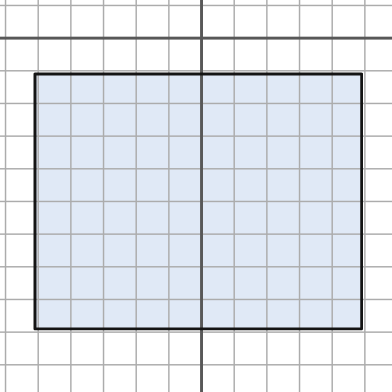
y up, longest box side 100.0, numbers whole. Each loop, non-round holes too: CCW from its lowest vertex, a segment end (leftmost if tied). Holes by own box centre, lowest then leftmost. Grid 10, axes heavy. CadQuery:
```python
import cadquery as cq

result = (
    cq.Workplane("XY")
    .moveTo(-51.0, -89.0)
    .lineTo(49.0, -89.0)
    .lineTo(49.0, -11.0)
    .lineTo(-51.0, -11.0)
    .close()
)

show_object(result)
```